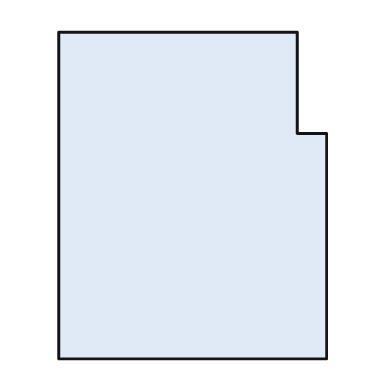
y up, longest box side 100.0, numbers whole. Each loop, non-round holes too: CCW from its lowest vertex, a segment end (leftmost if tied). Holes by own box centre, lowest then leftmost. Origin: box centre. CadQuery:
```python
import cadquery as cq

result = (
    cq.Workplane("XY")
    .moveTo(-41.0, -50.0)
    .lineTo(41.0, -50.0)
    .lineTo(41.0, 19.0)
    .lineTo(32.0, 19.0)
    .lineTo(32.0, 50.0)
    .lineTo(-41.0, 50.0)
    .close()
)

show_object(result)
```